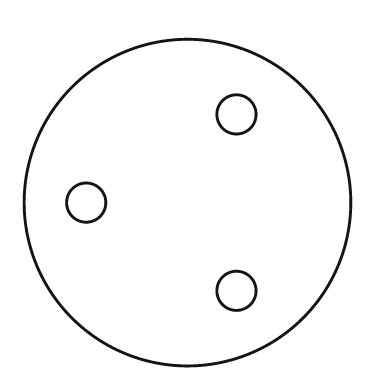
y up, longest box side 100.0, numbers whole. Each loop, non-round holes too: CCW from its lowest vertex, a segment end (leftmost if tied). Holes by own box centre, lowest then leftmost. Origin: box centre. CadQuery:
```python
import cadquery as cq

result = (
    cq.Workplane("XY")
    .moveTo(0.0, 0.0)
    .circle(50.0)
    .moveTo(15.0, -27.0)
    .circle(6.0)
    .moveTo(-31.0, 0.0)
    .circle(6.0)
    .moveTo(15.0, 27.0)
    .circle(6.0)
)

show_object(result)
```